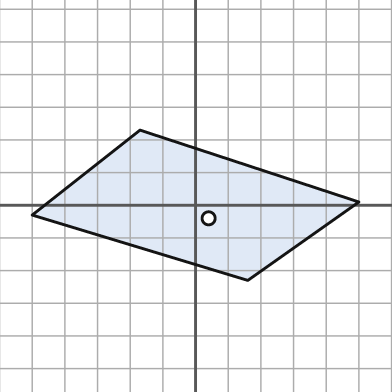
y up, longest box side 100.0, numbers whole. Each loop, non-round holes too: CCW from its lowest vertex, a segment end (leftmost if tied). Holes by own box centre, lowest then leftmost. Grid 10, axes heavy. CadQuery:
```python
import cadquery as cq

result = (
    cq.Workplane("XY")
    .moveTo(16.0, -23.0)
    .lineTo(50.0, 1.0)
    .lineTo(-17.0, 23.0)
    .lineTo(-50.0, -3.0)
    .close()
    .moveTo(4.0, -4.0)
    .circle(2.0)
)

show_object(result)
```